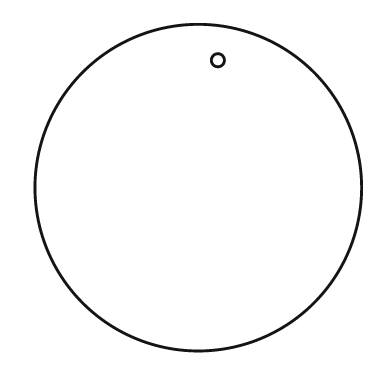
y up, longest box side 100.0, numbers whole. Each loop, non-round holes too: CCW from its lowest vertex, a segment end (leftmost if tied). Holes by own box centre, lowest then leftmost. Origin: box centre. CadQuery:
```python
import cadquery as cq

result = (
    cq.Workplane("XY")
    .moveTo(0.0, 0.0)
    .circle(50.0)
    .moveTo(6.0, 39.0)
    .circle(2.0)
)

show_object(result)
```